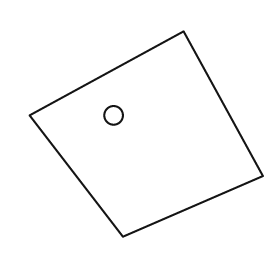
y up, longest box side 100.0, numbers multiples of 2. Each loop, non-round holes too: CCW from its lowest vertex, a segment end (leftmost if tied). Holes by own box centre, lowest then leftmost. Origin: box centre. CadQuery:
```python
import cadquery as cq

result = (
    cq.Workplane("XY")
    .moveTo(-10.0, -44.0)
    .lineTo(50.0, -18.0)
    .lineTo(16.0, 44.0)
    .lineTo(-50.0, 8.0)
    .close()
    .moveTo(-14.0, 8.0)
    .circle(4.0)
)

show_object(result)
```